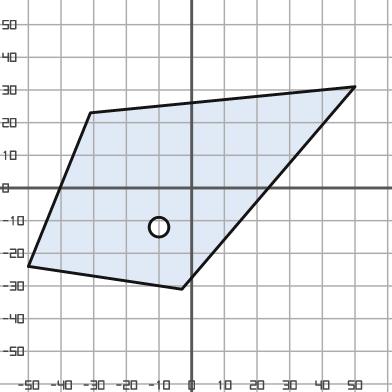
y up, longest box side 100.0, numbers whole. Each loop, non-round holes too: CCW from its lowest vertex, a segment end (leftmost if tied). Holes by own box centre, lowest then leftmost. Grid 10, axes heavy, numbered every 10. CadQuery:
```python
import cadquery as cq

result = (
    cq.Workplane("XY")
    .moveTo(-3.0, -31.0)
    .lineTo(50.0, 31.0)
    .lineTo(-31.0, 23.0)
    .lineTo(-50.0, -24.0)
    .close()
    .moveTo(-10.0, -12.0)
    .circle(3.0)
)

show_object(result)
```